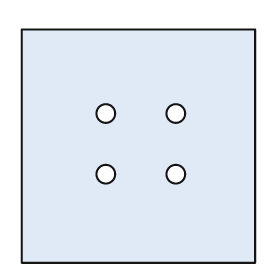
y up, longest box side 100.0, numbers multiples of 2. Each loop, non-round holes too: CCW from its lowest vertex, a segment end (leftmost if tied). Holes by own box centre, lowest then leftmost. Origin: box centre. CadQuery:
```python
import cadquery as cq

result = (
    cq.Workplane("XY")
    .moveTo(-50.0, -50.0)
    .lineTo(50.0, -50.0)
    .lineTo(50.0, 50.0)
    .lineTo(-50.0, 50.0)
    .close()
    .moveTo(-14.0, -12.0)
    .circle(4.0)
    .moveTo(16.0, -12.0)
    .circle(4.0)
    .moveTo(-14.0, 14.0)
    .circle(4.0)
    .moveTo(16.0, 14.0)
    .circle(4.0)
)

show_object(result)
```